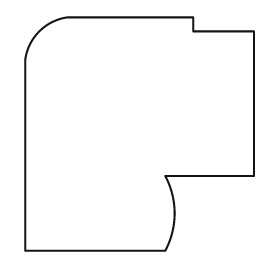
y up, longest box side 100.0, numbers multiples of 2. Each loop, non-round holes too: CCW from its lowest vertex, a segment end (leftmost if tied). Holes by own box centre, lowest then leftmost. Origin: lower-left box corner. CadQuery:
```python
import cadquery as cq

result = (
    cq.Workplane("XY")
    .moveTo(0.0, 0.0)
    .lineTo(60.0, 0.0)
    .threePointArc((64.0, 16.0), (60.0, 32.0))
    .lineTo(98.0, 32.0)
    .lineTo(98.0, 94.0)
    .lineTo(72.0, 94.0)
    .lineTo(72.0, 100.0)
    .lineTo(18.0, 100.0)
    .threePointArc((6.0, 94.0), (0.0, 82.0))
    .close()
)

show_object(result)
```